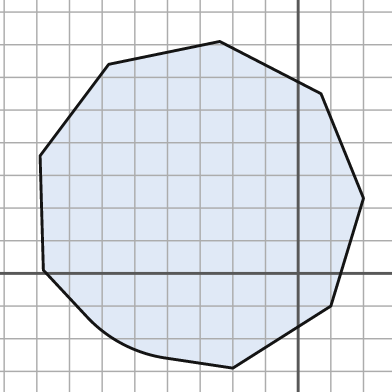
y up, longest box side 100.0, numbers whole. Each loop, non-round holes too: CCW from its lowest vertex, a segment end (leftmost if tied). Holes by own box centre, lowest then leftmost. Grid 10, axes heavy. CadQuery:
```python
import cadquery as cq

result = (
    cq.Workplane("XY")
    .moveTo(-20.0, -29.0)
    .lineTo(10.0, -10.0)
    .lineTo(20.0, 23.0)
    .lineTo(7.0, 55.0)
    .lineTo(-24.0, 71.0)
    .lineTo(-58.0, 64.0)
    .lineTo(-79.0, 36.0)
    .lineTo(-78.0, 1.0)
    .lineTo(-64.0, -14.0)
    .threePointArc((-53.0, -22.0), (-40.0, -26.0))
    .close()
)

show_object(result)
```